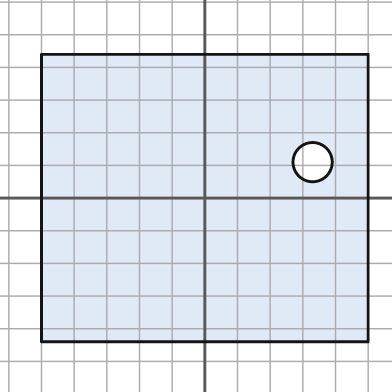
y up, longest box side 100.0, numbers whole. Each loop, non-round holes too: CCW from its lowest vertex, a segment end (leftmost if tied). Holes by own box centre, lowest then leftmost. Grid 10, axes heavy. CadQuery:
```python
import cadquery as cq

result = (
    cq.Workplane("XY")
    .moveTo(-50.0, -44.0)
    .lineTo(50.0, -44.0)
    .lineTo(50.0, 44.0)
    .lineTo(-50.0, 44.0)
    .close()
    .moveTo(33.0, 11.0)
    .circle(6.0)
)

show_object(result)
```